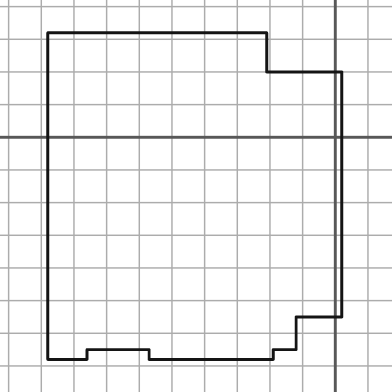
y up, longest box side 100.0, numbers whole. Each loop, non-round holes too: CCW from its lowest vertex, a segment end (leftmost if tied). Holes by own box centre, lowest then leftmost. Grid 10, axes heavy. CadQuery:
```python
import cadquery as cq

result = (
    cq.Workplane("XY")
    .moveTo(-88.0, -68.0)
    .lineTo(-76.0, -68.0)
    .lineTo(-76.0, -65.0)
    .lineTo(-57.0, -65.0)
    .lineTo(-57.0, -68.0)
    .lineTo(-19.0, -68.0)
    .lineTo(-19.0, -65.0)
    .lineTo(-12.0, -65.0)
    .lineTo(-12.0, -55.0)
    .lineTo(2.0, -55.0)
    .lineTo(2.0, 20.0)
    .lineTo(-21.0, 20.0)
    .lineTo(-21.0, 32.0)
    .lineTo(-88.0, 32.0)
    .close()
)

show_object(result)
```